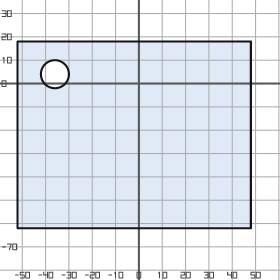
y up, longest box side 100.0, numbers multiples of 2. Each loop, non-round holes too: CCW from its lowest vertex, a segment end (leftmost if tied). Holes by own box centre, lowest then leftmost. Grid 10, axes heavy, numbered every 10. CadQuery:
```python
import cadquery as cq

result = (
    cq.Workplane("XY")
    .moveTo(-52.0, -62.0)
    .lineTo(48.0, -62.0)
    .lineTo(48.0, 18.0)
    .lineTo(-52.0, 18.0)
    .close()
    .moveTo(-36.0, 4.0)
    .circle(6.0)
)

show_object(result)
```